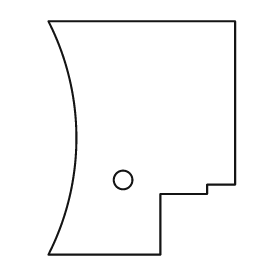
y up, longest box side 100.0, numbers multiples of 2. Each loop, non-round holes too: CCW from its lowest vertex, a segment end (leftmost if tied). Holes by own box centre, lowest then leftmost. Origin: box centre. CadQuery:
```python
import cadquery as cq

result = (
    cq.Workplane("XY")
    .moveTo(-40.0, -50.0)
    .lineTo(8.0, -50.0)
    .lineTo(8.0, -24.0)
    .lineTo(28.0, -24.0)
    .lineTo(28.0, -20.0)
    .lineTo(40.0, -20.0)
    .lineTo(40.0, 50.0)
    .lineTo(-40.0, 50.0)
    .threePointArc((-28.0, 0.0), (-40.0, -50.0))
    .close()
    .moveTo(-8.0, -18.0)
    .circle(4.0)
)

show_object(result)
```